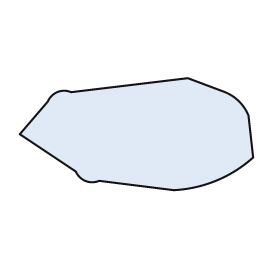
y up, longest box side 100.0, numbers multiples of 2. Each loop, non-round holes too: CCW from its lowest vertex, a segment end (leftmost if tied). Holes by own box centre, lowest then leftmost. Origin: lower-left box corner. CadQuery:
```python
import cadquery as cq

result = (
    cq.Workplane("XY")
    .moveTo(66.0, 0.0)
    .threePointArc((84.0, 4.0), (100.0, 14.0))
    .lineTo(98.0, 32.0)
    .threePointArc((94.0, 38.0), (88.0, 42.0))
    .lineTo(72.0, 48.0)
    .lineTo(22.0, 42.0)
    .threePointArc((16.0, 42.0), (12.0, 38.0))
    .lineTo(0.0, 24.0)
    .lineTo(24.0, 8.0)
    .threePointArc((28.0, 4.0), (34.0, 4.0))
    .close()
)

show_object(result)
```